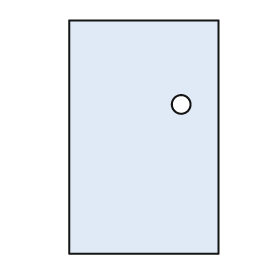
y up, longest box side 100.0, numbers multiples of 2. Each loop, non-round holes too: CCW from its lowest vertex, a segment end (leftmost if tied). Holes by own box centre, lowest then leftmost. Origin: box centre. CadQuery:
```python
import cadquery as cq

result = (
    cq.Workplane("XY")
    .moveTo(-32.0, -50.0)
    .lineTo(32.0, -50.0)
    .lineTo(32.0, 50.0)
    .lineTo(-32.0, 50.0)
    .close()
    .moveTo(16.0, 14.0)
    .circle(4.0)
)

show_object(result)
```